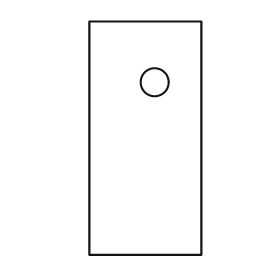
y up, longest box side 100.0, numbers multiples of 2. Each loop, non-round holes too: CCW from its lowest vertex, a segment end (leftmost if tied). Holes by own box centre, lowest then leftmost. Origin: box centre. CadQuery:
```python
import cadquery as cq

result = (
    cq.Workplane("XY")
    .moveTo(-24.0, -50.0)
    .lineTo(24.0, -50.0)
    .lineTo(24.0, 50.0)
    .lineTo(-24.0, 50.0)
    .close()
    .moveTo(4.0, 24.0)
    .circle(6.0)
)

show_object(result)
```